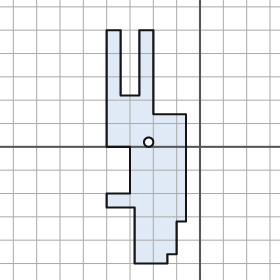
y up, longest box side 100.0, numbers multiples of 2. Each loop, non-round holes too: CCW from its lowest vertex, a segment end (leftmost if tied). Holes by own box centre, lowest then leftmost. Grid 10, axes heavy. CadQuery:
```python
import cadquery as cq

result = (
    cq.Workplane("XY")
    .moveTo(-28.0, -50.0)
    .lineTo(-14.0, -50.0)
    .lineTo(-14.0, -46.0)
    .lineTo(-10.0, -46.0)
    .lineTo(-10.0, -32.0)
    .lineTo(-6.0, -32.0)
    .lineTo(-6.0, 14.0)
    .lineTo(-20.0, 14.0)
    .lineTo(-20.0, 50.0)
    .lineTo(-26.0, 50.0)
    .lineTo(-26.0, 22.0)
    .lineTo(-34.0, 22.0)
    .lineTo(-34.0, 50.0)
    .lineTo(-40.0, 50.0)
    .lineTo(-40.0, 0.0)
    .lineTo(-30.0, 0.0)
    .lineTo(-30.0, -20.0)
    .lineTo(-40.0, -20.0)
    .lineTo(-40.0, -26.0)
    .lineTo(-28.0, -26.0)
    .close()
    .moveTo(-22.0, 2.0)
    .circle(2.0)
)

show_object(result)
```